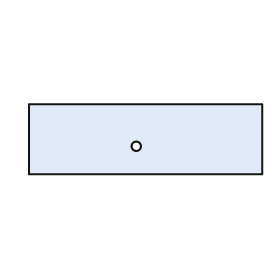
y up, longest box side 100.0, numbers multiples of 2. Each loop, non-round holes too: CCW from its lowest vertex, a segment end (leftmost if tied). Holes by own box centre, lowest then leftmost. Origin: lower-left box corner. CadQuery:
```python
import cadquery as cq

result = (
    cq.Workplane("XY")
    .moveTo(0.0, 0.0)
    .lineTo(100.0, 0.0)
    .lineTo(100.0, 30.0)
    .lineTo(0.0, 30.0)
    .close()
    .moveTo(46.0, 12.0)
    .circle(2.0)
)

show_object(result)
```